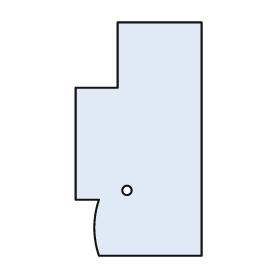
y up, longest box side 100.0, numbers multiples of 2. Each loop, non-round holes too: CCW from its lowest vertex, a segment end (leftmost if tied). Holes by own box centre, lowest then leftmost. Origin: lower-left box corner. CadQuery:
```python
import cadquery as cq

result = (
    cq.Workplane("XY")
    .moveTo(10.0, 0.0)
    .lineTo(54.0, 0.0)
    .lineTo(54.0, 100.0)
    .lineTo(18.0, 100.0)
    .lineTo(18.0, 72.0)
    .lineTo(0.0, 72.0)
    .lineTo(0.0, 24.0)
    .lineTo(10.0, 24.0)
    .threePointArc((8.0, 12.0), (10.0, 0.0))
    .close()
    .moveTo(22.0, 28.0)
    .circle(2.0)
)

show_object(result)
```